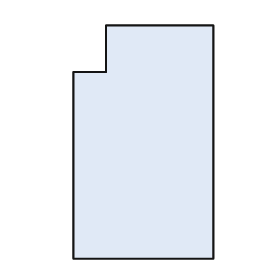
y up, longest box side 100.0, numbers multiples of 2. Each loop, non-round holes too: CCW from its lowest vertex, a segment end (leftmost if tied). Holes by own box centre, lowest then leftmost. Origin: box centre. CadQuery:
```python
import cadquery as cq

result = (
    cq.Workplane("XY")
    .moveTo(-30.0, -50.0)
    .lineTo(30.0, -50.0)
    .lineTo(30.0, 50.0)
    .lineTo(-16.0, 50.0)
    .lineTo(-16.0, 30.0)
    .lineTo(-30.0, 30.0)
    .close()
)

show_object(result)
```